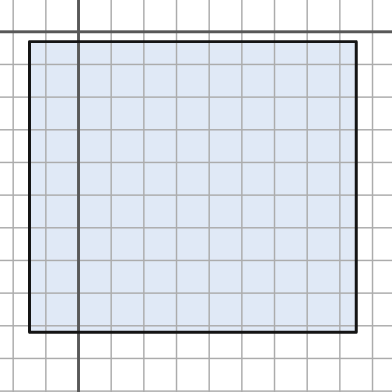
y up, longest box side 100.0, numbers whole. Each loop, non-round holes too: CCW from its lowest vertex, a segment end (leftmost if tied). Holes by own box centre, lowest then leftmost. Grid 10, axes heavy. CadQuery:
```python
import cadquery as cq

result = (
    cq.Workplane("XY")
    .moveTo(-15.0, -92.0)
    .lineTo(85.0, -92.0)
    .lineTo(85.0, -3.0)
    .lineTo(-15.0, -3.0)
    .close()
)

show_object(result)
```